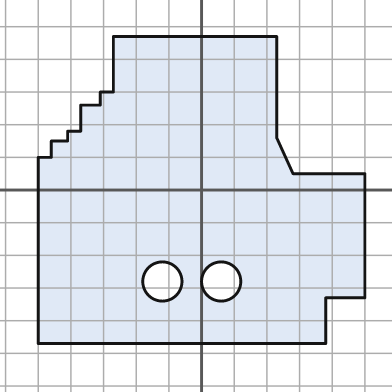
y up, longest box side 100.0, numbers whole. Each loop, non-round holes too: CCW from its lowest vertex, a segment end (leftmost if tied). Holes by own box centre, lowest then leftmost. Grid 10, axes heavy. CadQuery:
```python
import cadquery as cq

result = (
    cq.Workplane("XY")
    .moveTo(-50.0, -47.0)
    .lineTo(38.0, -47.0)
    .lineTo(38.0, -33.0)
    .lineTo(50.0, -33.0)
    .lineTo(50.0, 5.0)
    .lineTo(28.0, 5.0)
    .lineTo(23.0, 16.0)
    .lineTo(23.0, 47.0)
    .lineTo(-27.0, 47.0)
    .lineTo(-27.0, 30.0)
    .lineTo(-31.0, 30.0)
    .lineTo(-31.0, 26.0)
    .lineTo(-37.0, 26.0)
    .lineTo(-37.0, 18.0)
    .lineTo(-41.0, 18.0)
    .lineTo(-41.0, 15.0)
    .lineTo(-46.0, 15.0)
    .lineTo(-46.0, 10.0)
    .lineTo(-50.0, 10.0)
    .close()
    .moveTo(-12.0, -28.0)
    .circle(6.0)
    .moveTo(6.0, -28.0)
    .circle(6.0)
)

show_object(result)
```